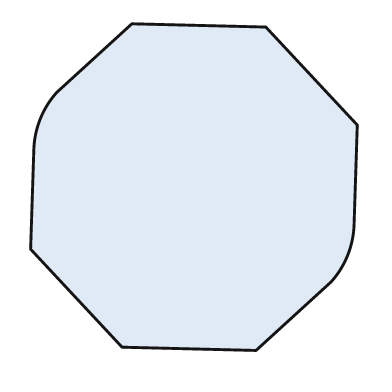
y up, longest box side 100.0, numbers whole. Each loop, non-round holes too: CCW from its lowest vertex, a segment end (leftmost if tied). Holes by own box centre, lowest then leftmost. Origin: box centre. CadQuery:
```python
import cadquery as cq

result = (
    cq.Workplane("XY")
    .moveTo(19.0, -50.0)
    .lineTo(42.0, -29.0)
    .threePointArc((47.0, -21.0), (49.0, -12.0))
    .lineTo(50.0, 19.0)
    .lineTo(22.0, 49.0)
    .lineTo(-19.0, 50.0)
    .lineTo(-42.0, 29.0)
    .threePointArc((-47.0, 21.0), (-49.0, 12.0))
    .lineTo(-50.0, -19.0)
    .lineTo(-22.0, -49.0)
    .close()
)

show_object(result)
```